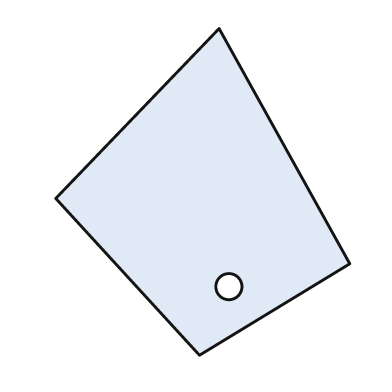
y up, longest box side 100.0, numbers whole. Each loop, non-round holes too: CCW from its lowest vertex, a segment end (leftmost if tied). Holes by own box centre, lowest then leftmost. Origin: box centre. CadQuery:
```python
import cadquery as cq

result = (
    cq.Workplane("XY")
    .moveTo(-1.0, -50.0)
    .lineTo(45.0, -22.0)
    .lineTo(5.0, 50.0)
    .lineTo(-45.0, -2.0)
    .close()
    .moveTo(8.0, -29.0)
    .circle(4.0)
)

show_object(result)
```